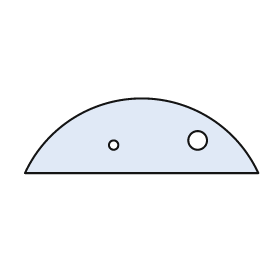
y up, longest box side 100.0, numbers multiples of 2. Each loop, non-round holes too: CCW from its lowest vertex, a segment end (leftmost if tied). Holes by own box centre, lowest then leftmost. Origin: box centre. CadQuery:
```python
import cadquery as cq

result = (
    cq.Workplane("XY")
    .moveTo(-50.0, -16.0)
    .lineTo(50.0, -16.0)
    .threePointArc((0.0, 16.0), (-50.0, -16.0))
    .close()
    .moveTo(-12.0, -4.0)
    .circle(2.0)
    .moveTo(24.0, -2.0)
    .circle(4.0)
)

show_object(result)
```